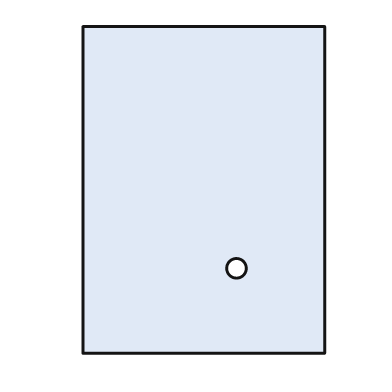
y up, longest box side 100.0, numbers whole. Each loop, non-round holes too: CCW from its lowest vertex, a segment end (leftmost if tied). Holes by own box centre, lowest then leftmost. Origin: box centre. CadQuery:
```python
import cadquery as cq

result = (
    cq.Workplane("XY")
    .moveTo(-37.0, -50.0)
    .lineTo(37.0, -50.0)
    .lineTo(37.0, 50.0)
    .lineTo(-37.0, 50.0)
    .close()
    .moveTo(10.0, -24.0)
    .circle(3.0)
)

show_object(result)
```